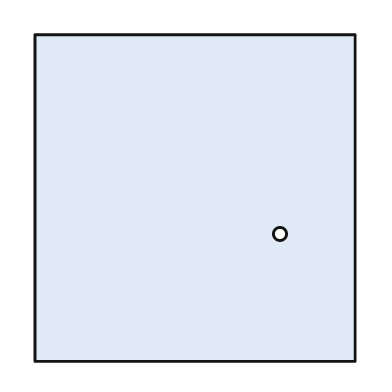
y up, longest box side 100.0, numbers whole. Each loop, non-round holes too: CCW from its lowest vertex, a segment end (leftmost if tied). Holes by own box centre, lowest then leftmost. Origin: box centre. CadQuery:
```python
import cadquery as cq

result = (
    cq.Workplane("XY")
    .moveTo(-49.0, -50.0)
    .lineTo(49.0, -50.0)
    .lineTo(49.0, 50.0)
    .lineTo(-49.0, 50.0)
    .close()
    .moveTo(26.0, -11.0)
    .circle(2.0)
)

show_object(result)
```